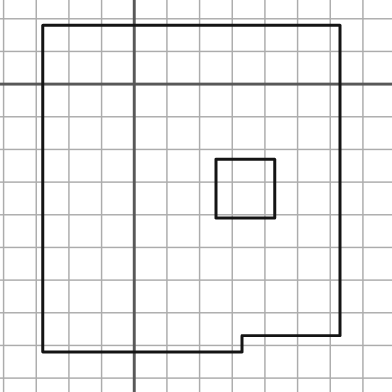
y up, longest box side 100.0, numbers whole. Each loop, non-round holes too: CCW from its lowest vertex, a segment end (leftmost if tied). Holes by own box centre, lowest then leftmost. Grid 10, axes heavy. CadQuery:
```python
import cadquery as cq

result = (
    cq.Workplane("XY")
    .moveTo(-28.0, -82.0)
    .lineTo(33.0, -82.0)
    .lineTo(33.0, -77.0)
    .lineTo(63.0, -77.0)
    .lineTo(63.0, 18.0)
    .lineTo(-28.0, 18.0)
    .close()
    .moveTo(25.0, -41.0)
    .lineTo(43.0, -41.0)
    .lineTo(43.0, -23.0)
    .lineTo(25.0, -23.0)
    .close()
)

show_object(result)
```